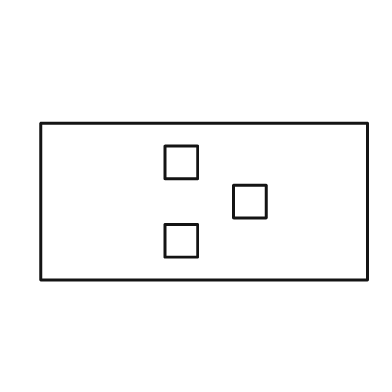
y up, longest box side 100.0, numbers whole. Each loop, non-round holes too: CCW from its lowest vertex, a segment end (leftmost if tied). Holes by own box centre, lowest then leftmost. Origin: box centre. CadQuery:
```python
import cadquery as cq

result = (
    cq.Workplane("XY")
    .moveTo(-50.0, -24.0)
    .lineTo(50.0, -24.0)
    .lineTo(50.0, 24.0)
    .lineTo(-50.0, 24.0)
    .close()
    .moveTo(-12.0, -17.0)
    .lineTo(-2.0, -17.0)
    .lineTo(-2.0, -7.0)
    .lineTo(-12.0, -7.0)
    .close()
    .moveTo(9.0, -5.0)
    .lineTo(19.0, -5.0)
    .lineTo(19.0, 5.0)
    .lineTo(9.0, 5.0)
    .close()
    .moveTo(-12.0, 7.0)
    .lineTo(-2.0, 7.0)
    .lineTo(-2.0, 17.0)
    .lineTo(-12.0, 17.0)
    .close()
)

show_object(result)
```